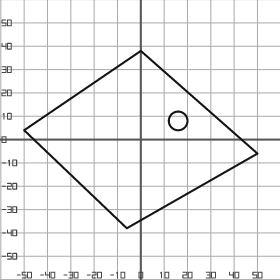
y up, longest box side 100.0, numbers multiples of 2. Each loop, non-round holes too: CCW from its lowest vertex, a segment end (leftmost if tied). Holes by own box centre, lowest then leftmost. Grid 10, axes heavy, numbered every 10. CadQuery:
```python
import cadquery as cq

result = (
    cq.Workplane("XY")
    .moveTo(-6.0, -38.0)
    .lineTo(50.0, -6.0)
    .lineTo(0.0, 38.0)
    .lineTo(-50.0, 4.0)
    .close()
    .moveTo(16.0, 8.0)
    .circle(4.0)
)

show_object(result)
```